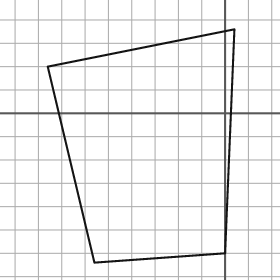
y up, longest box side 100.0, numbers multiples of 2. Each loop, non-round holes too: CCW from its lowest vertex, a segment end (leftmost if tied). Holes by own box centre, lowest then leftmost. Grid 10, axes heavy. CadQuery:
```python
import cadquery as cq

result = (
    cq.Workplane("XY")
    .moveTo(-56.0, -64.0)
    .lineTo(0.0, -60.0)
    .lineTo(4.0, 36.0)
    .lineTo(-76.0, 20.0)
    .close()
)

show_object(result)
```